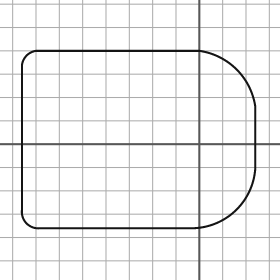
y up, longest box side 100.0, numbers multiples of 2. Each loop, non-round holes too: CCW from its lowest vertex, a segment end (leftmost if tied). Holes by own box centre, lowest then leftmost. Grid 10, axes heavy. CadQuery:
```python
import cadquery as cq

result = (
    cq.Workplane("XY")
    .moveTo(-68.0, -36.0)
    .lineTo(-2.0, -36.0)
    .threePointArc((16.0, -28.0), (24.0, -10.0))
    .lineTo(24.0, 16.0)
    .threePointArc((16.0, 32.0), (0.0, 40.0))
    .lineTo(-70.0, 40.0)
    .threePointArc((-74.0, 38.0), (-76.0, 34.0))
    .lineTo(-76.0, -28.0)
    .threePointArc((-74.0, -34.0), (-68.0, -36.0))
    .close()
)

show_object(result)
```